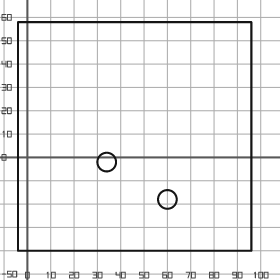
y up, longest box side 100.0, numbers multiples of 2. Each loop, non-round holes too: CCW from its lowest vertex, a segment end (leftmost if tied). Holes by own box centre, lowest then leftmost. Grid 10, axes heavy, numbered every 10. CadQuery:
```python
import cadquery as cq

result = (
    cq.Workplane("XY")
    .moveTo(-4.0, -40.0)
    .lineTo(96.0, -40.0)
    .lineTo(96.0, 58.0)
    .lineTo(-4.0, 58.0)
    .close()
    .moveTo(60.0, -18.0)
    .circle(4.0)
    .moveTo(34.0, -2.0)
    .circle(4.0)
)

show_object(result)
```